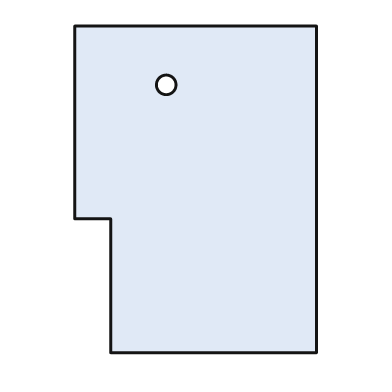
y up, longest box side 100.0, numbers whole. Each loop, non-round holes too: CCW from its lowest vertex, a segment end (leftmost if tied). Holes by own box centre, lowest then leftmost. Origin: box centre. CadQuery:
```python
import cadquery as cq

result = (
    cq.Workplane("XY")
    .moveTo(-26.0, -50.0)
    .lineTo(37.0, -50.0)
    .lineTo(37.0, 50.0)
    .lineTo(-37.0, 50.0)
    .lineTo(-37.0, -9.0)
    .lineTo(-26.0, -9.0)
    .close()
    .moveTo(-9.0, 32.0)
    .circle(3.0)
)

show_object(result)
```